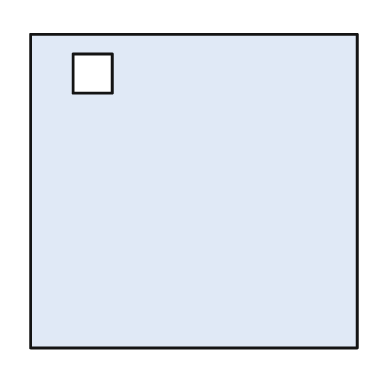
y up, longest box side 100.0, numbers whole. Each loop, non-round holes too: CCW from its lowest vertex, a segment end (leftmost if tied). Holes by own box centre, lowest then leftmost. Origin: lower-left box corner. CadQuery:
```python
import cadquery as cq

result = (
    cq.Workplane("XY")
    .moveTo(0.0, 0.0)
    .lineTo(100.0, 0.0)
    .lineTo(100.0, 96.0)
    .lineTo(0.0, 96.0)
    .close()
    .moveTo(13.0, 78.0)
    .lineTo(25.0, 78.0)
    .lineTo(25.0, 90.0)
    .lineTo(13.0, 90.0)
    .close()
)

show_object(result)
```